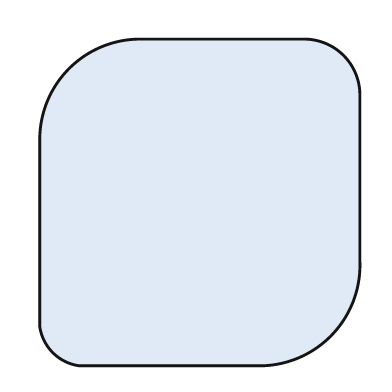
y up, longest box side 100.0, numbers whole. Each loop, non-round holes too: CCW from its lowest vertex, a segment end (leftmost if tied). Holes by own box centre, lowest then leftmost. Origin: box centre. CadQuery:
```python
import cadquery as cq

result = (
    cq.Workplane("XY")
    .moveTo(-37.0, -50.0)
    .lineTo(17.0, -50.0)
    .threePointArc((40.0, -41.0), (49.0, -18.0))
    .lineTo(49.0, 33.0)
    .threePointArc((44.0, 45.0), (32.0, 50.0))
    .lineTo(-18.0, 50.0)
    .threePointArc((-40.0, 41.0), (-49.0, 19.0))
    .lineTo(-49.0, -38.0)
    .threePointArc((-45.0, -46.0), (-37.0, -50.0))
    .close()
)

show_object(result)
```